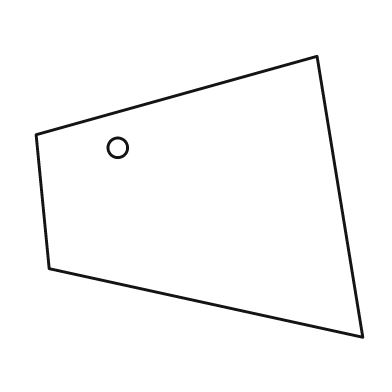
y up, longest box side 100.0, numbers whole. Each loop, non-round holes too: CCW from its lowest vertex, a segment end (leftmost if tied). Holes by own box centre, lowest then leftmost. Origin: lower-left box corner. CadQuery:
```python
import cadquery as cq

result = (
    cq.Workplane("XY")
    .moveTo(100.0, 0.0)
    .lineTo(86.0, 86.0)
    .lineTo(0.0, 62.0)
    .lineTo(4.0, 21.0)
    .close()
    .moveTo(25.0, 58.0)
    .circle(3.0)
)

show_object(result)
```